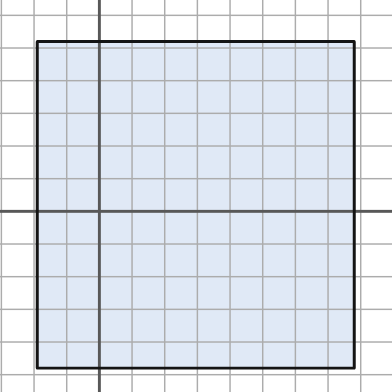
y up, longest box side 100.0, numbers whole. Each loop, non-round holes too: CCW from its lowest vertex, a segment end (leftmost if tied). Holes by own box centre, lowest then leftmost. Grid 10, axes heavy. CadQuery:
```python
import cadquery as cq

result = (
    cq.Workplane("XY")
    .moveTo(-19.0, -48.0)
    .lineTo(78.0, -48.0)
    .lineTo(78.0, 52.0)
    .lineTo(-19.0, 52.0)
    .close()
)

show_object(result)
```